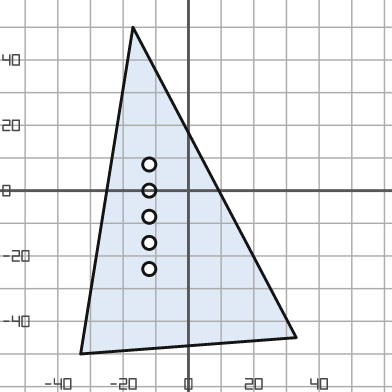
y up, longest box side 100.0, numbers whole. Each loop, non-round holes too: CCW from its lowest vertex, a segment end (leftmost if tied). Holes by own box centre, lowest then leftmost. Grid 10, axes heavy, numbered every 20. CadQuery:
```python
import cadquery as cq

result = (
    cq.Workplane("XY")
    .moveTo(-33.0, -50.0)
    .lineTo(33.0, -45.0)
    .lineTo(-17.0, 50.0)
    .close()
    .moveTo(-12.0, -24.0)
    .circle(2.0)
    .moveTo(-12.0, -16.0)
    .circle(2.0)
    .moveTo(-12.0, -8.0)
    .circle(2.0)
    .moveTo(-12.0, 0.0)
    .circle(2.0)
    .moveTo(-12.0, 8.0)
    .circle(2.0)
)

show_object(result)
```